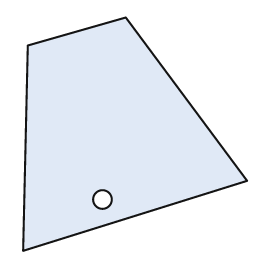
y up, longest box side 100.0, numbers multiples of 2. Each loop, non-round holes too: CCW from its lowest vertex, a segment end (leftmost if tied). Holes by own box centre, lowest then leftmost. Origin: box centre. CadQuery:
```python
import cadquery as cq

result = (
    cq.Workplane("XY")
    .moveTo(-48.0, -50.0)
    .lineTo(48.0, -20.0)
    .lineTo(-4.0, 50.0)
    .lineTo(-46.0, 38.0)
    .close()
    .moveTo(-14.0, -28.0)
    .circle(4.0)
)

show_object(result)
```